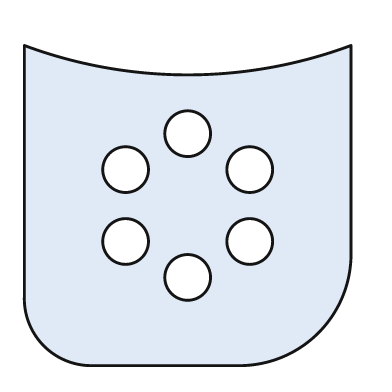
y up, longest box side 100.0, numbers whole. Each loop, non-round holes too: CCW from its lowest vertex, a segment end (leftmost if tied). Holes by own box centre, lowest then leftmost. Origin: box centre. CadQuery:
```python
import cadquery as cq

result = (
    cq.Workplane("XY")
    .moveTo(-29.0, -49.0)
    .lineTo(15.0, -49.0)
    .threePointArc((40.0, -39.0), (50.0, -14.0))
    .lineTo(50.0, 49.0)
    .threePointArc((0.0, 40.0), (-50.0, 49.0))
    .lineTo(-50.0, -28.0)
    .threePointArc((-44.0, -43.0), (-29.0, -49.0))
    .close()
    .moveTo(0.0, -22.0)
    .circle(7.0)
    .moveTo(-19.0, -11.0)
    .circle(7.0)
    .moveTo(19.0, -11.0)
    .circle(7.0)
    .moveTo(-19.0, 11.0)
    .circle(7.0)
    .moveTo(19.0, 11.0)
    .circle(7.0)
    .moveTo(0.0, 22.0)
    .circle(7.0)
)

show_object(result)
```